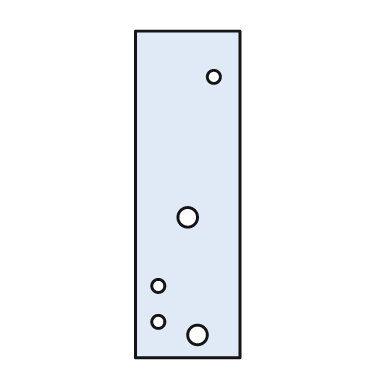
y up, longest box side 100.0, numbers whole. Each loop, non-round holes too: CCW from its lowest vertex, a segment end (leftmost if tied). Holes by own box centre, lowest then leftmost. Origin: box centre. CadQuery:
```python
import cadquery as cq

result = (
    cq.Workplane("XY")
    .moveTo(-16.0, -50.0)
    .lineTo(16.0, -50.0)
    .lineTo(16.0, 50.0)
    .lineTo(-16.0, 50.0)
    .close()
    .moveTo(3.0, -43.0)
    .circle(3.0)
    .moveTo(-9.0, -39.0)
    .circle(2.0)
    .moveTo(-9.0, -28.0)
    .circle(2.0)
    .moveTo(0.0, -7.0)
    .circle(3.0)
    .moveTo(8.0, 36.0)
    .circle(2.0)
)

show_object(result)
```